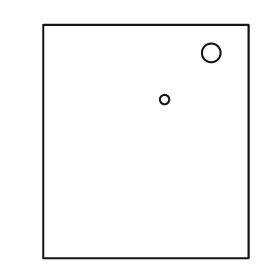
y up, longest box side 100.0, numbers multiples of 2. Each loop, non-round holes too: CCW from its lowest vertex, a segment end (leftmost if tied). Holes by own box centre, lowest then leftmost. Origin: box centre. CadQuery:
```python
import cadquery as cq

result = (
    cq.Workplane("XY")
    .moveTo(-44.0, -50.0)
    .lineTo(44.0, -50.0)
    .lineTo(44.0, 50.0)
    .lineTo(-44.0, 50.0)
    .close()
    .moveTo(8.0, 18.0)
    .circle(2.0)
    .moveTo(28.0, 38.0)
    .circle(4.0)
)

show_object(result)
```